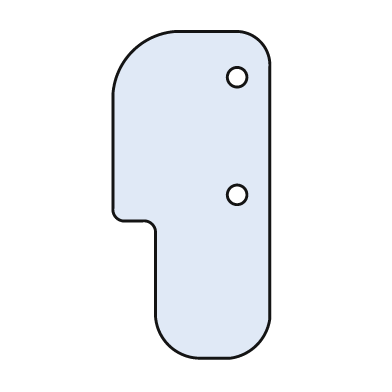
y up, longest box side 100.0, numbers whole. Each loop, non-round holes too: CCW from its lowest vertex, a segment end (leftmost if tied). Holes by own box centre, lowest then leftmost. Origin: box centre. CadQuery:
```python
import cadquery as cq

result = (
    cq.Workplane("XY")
    .moveTo(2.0, -50.0)
    .lineTo(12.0, -50.0)
    .threePointArc((20.0, -46.0), (24.0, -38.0))
    .lineTo(24.0, 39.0)
    .threePointArc((21.0, 47.0), (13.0, 50.0))
    .lineTo(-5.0, 50.0)
    .threePointArc((-18.0, 44.0), (-24.0, 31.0))
    .lineTo(-24.0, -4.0)
    .threePointArc((-23.0, -7.0), (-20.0, -8.0))
    .lineTo(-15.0, -8.0)
    .threePointArc((-12.0, -9.0), (-11.0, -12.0))
    .lineTo(-11.0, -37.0)
    .threePointArc((-7.0, -46.0), (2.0, -50.0))
    .close()
    .moveTo(14.0, 0.0)
    .circle(3.0)
    .moveTo(14.0, 36.0)
    .circle(3.0)
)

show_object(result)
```